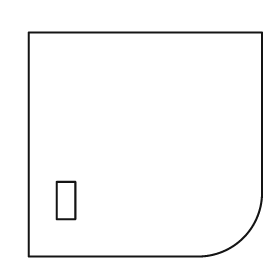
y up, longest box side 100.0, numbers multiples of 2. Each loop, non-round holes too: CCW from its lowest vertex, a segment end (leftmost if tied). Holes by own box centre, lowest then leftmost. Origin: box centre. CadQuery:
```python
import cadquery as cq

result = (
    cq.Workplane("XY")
    .moveTo(-50.0, -48.0)
    .lineTo(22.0, -48.0)
    .threePointArc((42.0, -40.0), (50.0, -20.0))
    .lineTo(50.0, 48.0)
    .lineTo(-50.0, 48.0)
    .close()
    .moveTo(-38.0, -32.0)
    .lineTo(-30.0, -32.0)
    .lineTo(-30.0, -16.0)
    .lineTo(-38.0, -16.0)
    .close()
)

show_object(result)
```